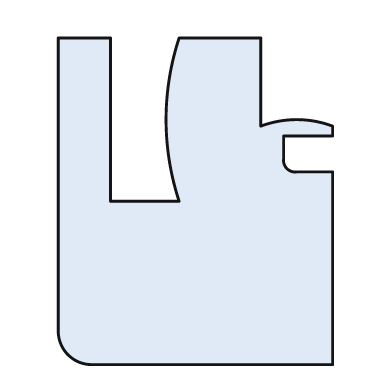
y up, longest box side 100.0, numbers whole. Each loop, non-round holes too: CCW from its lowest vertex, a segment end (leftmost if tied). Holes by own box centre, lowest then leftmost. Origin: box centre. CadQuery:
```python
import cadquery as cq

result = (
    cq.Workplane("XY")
    .moveTo(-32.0, -50.0)
    .lineTo(42.0, -50.0)
    .lineTo(42.0, 9.0)
    .lineTo(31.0, 9.0)
    .threePointArc((28.0, 10.0), (27.0, 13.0))
    .lineTo(27.0, 20.0)
    .lineTo(42.0, 20.0)
    .lineTo(42.0, 23.0)
    .threePointArc((31.0, 25.0), (20.0, 23.0))
    .lineTo(20.0, 50.0)
    .lineTo(-5.0, 50.0)
    .threePointArc((-9.0, 25.0), (-5.0, 0.0))
    .lineTo(-26.0, 0.0)
    .lineTo(-26.0, 50.0)
    .lineTo(-42.0, 50.0)
    .lineTo(-42.0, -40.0)
    .threePointArc((-39.0, -47.0), (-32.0, -50.0))
    .close()
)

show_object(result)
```